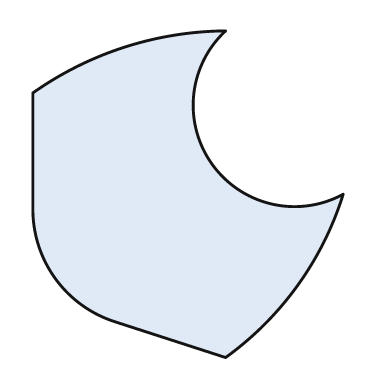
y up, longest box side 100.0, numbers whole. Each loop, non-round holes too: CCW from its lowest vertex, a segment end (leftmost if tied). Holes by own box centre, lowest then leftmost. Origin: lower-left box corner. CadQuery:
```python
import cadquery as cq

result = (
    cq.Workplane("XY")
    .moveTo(59.0, 0.0)
    .threePointArc((81.0, 22.0), (95.0, 50.0))
    .threePointArc((55.0, 59.0), (59.0, 100.0))
    .threePointArc((28.0, 95.0), (0.0, 81.0))
    .lineTo(0.0, 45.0)
    .threePointArc((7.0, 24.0), (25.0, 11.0))
    .close()
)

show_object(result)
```